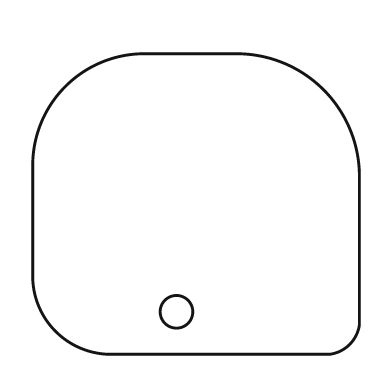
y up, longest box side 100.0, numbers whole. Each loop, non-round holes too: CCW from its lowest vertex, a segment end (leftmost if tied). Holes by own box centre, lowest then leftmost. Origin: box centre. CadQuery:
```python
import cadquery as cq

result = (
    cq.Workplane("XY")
    .moveTo(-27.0, -46.0)
    .lineTo(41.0, -46.0)
    .threePointArc((47.0, -43.0), (50.0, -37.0))
    .lineTo(50.0, 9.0)
    .threePointArc((39.0, 35.0), (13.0, 46.0))
    .lineTo(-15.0, 46.0)
    .threePointArc((-40.0, 36.0), (-50.0, 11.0))
    .lineTo(-50.0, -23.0)
    .threePointArc((-43.0, -39.0), (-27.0, -46.0))
    .close()
    .moveTo(-6.0, -33.0)
    .circle(5.0)
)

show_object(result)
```